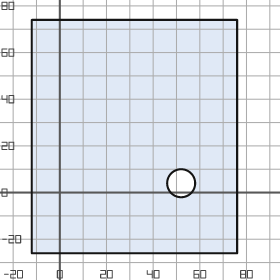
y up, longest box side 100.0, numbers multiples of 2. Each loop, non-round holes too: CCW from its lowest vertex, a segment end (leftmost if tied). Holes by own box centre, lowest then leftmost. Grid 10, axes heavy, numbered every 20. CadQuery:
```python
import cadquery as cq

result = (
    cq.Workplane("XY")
    .moveTo(-12.0, -26.0)
    .lineTo(76.0, -26.0)
    .lineTo(76.0, 74.0)
    .lineTo(-12.0, 74.0)
    .close()
    .moveTo(52.0, 4.0)
    .circle(6.0)
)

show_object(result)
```